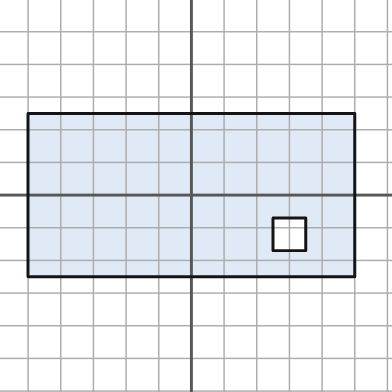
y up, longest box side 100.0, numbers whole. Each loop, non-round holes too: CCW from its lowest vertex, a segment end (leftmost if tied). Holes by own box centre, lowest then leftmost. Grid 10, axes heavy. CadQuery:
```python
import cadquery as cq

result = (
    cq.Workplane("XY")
    .moveTo(-50.0, -25.0)
    .lineTo(50.0, -25.0)
    .lineTo(50.0, 25.0)
    .lineTo(-50.0, 25.0)
    .close()
    .moveTo(25.0, -17.0)
    .lineTo(35.0, -17.0)
    .lineTo(35.0, -7.0)
    .lineTo(25.0, -7.0)
    .close()
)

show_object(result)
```